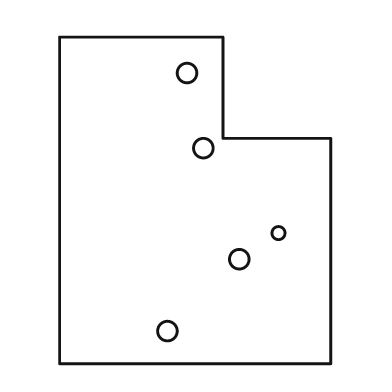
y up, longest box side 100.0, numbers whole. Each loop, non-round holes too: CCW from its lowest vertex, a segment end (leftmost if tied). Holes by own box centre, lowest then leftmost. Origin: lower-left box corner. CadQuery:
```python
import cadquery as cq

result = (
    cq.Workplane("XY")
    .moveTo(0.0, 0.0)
    .lineTo(83.0, 0.0)
    .lineTo(83.0, 69.0)
    .lineTo(50.0, 69.0)
    .lineTo(50.0, 100.0)
    .lineTo(0.0, 100.0)
    .close()
    .moveTo(33.0, 10.0)
    .circle(3.0)
    .moveTo(55.0, 32.0)
    .circle(3.0)
    .moveTo(67.0, 40.0)
    .circle(2.0)
    .moveTo(44.0, 66.0)
    .circle(3.0)
    .moveTo(39.0, 89.0)
    .circle(3.0)
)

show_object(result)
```